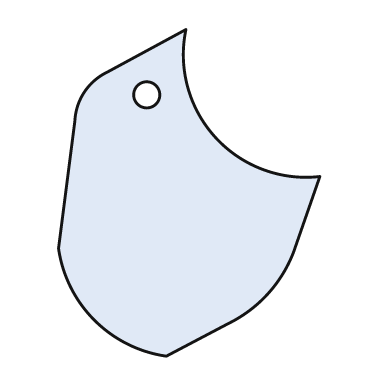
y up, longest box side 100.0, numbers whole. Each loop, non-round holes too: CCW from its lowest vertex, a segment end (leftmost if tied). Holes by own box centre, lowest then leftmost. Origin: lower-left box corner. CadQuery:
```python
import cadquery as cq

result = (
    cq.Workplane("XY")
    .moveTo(33.0, 0.0)
    .lineTo(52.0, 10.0)
    .threePointArc((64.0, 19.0), (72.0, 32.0))
    .lineTo(80.0, 55.0)
    .threePointArc((48.0, 67.0), (39.0, 100.0))
    .lineTo(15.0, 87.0)
    .threePointArc((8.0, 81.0), (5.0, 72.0))
    .lineTo(0.0, 33.0)
    .threePointArc((11.0, 11.0), (33.0, 0.0))
    .close()
    .moveTo(27.0, 80.0)
    .circle(4.0)
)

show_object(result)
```